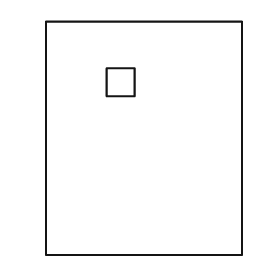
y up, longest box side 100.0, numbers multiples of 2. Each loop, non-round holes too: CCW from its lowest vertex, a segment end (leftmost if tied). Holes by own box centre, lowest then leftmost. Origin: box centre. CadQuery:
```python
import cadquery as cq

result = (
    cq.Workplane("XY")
    .moveTo(-42.0, -50.0)
    .lineTo(42.0, -50.0)
    .lineTo(42.0, 50.0)
    .lineTo(-42.0, 50.0)
    .close()
    .moveTo(-16.0, 18.0)
    .lineTo(-4.0, 18.0)
    .lineTo(-4.0, 30.0)
    .lineTo(-16.0, 30.0)
    .close()
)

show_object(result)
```